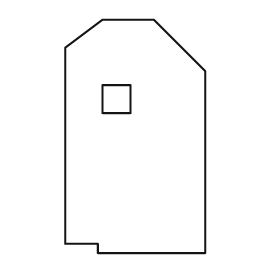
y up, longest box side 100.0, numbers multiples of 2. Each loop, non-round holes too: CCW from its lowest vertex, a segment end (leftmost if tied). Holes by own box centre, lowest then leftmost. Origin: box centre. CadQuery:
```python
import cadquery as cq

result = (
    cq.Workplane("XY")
    .moveTo(-16.0, -50.0)
    .lineTo(30.0, -50.0)
    .lineTo(30.0, 28.0)
    .lineTo(8.0, 50.0)
    .lineTo(-14.0, 50.0)
    .lineTo(-30.0, 38.0)
    .lineTo(-30.0, -46.0)
    .lineTo(-16.0, -46.0)
    .close()
    .moveTo(-14.0, 10.0)
    .lineTo(-2.0, 10.0)
    .lineTo(-2.0, 22.0)
    .lineTo(-14.0, 22.0)
    .close()
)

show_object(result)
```